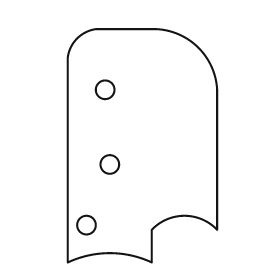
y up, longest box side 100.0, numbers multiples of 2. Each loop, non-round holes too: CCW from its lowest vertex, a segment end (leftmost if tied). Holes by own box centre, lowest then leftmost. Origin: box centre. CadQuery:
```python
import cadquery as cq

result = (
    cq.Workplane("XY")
    .moveTo(-32.0, -50.0)
    .threePointArc((-14.0, -46.0), (4.0, -50.0))
    .lineTo(4.0, -36.0)
    .threePointArc((18.0, -30.0), (32.0, -36.0))
    .lineTo(32.0, 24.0)
    .threePointArc((24.0, 42.0), (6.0, 50.0))
    .lineTo(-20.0, 50.0)
    .threePointArc((-28.0, 46.0), (-32.0, 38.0))
    .close()
    .moveTo(-24.0, -34.0)
    .circle(4.0)
    .moveTo(-14.0, -8.0)
    .circle(4.0)
    .moveTo(-16.0, 24.0)
    .circle(4.0)
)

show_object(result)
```